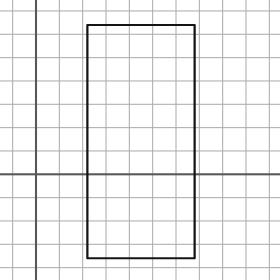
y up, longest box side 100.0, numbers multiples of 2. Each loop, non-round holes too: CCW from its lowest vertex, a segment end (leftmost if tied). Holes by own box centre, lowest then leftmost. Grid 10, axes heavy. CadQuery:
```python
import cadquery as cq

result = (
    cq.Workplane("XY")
    .moveTo(22.0, -36.0)
    .lineTo(68.0, -36.0)
    .lineTo(68.0, 64.0)
    .lineTo(22.0, 64.0)
    .close()
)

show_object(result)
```